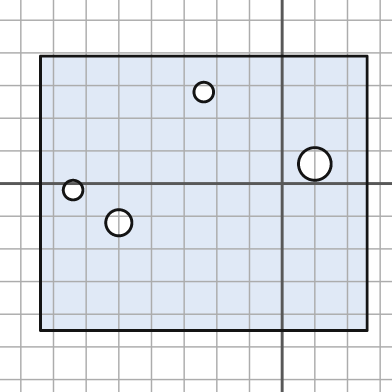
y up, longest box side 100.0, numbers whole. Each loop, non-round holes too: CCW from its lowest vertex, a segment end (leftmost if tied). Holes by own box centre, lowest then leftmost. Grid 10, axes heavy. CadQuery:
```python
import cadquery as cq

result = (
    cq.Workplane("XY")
    .moveTo(-74.0, -45.0)
    .lineTo(26.0, -45.0)
    .lineTo(26.0, 39.0)
    .lineTo(-74.0, 39.0)
    .close()
    .moveTo(-50.0, -12.0)
    .circle(4.0)
    .moveTo(-64.0, -2.0)
    .circle(3.0)
    .moveTo(10.0, 6.0)
    .circle(5.0)
    .moveTo(-24.0, 28.0)
    .circle(3.0)
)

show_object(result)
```